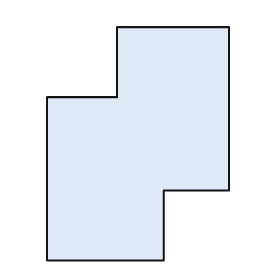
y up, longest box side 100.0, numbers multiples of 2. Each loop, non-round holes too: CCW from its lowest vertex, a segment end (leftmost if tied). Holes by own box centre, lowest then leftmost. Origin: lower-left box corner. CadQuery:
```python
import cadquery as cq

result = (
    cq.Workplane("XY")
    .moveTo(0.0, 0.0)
    .lineTo(50.0, 0.0)
    .lineTo(50.0, 30.0)
    .lineTo(78.0, 30.0)
    .lineTo(78.0, 100.0)
    .lineTo(30.0, 100.0)
    .lineTo(30.0, 70.0)
    .lineTo(0.0, 70.0)
    .close()
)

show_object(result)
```